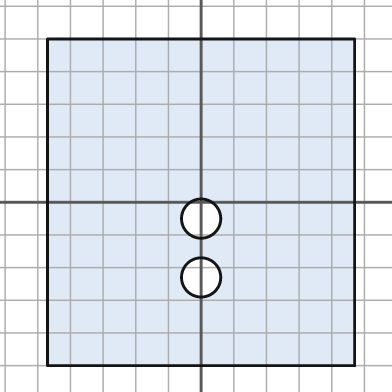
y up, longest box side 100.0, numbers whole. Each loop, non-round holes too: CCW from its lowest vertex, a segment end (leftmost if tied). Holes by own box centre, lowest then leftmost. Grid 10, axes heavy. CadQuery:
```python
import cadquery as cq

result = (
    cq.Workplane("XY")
    .moveTo(-47.0, -50.0)
    .lineTo(47.0, -50.0)
    .lineTo(47.0, 50.0)
    .lineTo(-47.0, 50.0)
    .close()
    .moveTo(0.0, -23.0)
    .circle(6.0)
    .moveTo(0.0, -5.0)
    .circle(6.0)
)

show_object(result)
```